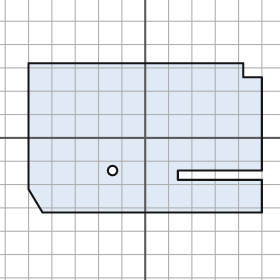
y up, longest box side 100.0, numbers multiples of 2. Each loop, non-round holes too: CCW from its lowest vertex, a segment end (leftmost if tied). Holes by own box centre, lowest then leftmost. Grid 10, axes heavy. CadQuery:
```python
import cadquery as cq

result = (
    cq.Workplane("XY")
    .moveTo(-44.0, -32.0)
    .lineTo(50.0, -32.0)
    .lineTo(50.0, -18.0)
    .lineTo(14.0, -18.0)
    .lineTo(14.0, -14.0)
    .lineTo(50.0, -14.0)
    .lineTo(50.0, 26.0)
    .lineTo(42.0, 26.0)
    .lineTo(42.0, 32.0)
    .lineTo(-50.0, 32.0)
    .lineTo(-50.0, -22.0)
    .close()
    .moveTo(-14.0, -14.0)
    .circle(2.0)
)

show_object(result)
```